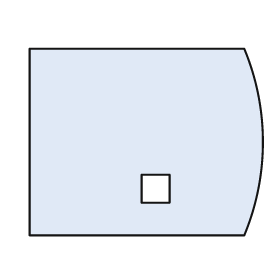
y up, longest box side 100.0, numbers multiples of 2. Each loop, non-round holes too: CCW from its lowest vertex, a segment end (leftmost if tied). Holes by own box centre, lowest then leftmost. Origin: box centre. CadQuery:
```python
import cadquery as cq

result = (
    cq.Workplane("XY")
    .moveTo(-50.0, -40.0)
    .lineTo(42.0, -40.0)
    .threePointArc((50.0, 0.0), (42.0, 40.0))
    .lineTo(-50.0, 40.0)
    .close()
    .moveTo(-2.0, -26.0)
    .lineTo(10.0, -26.0)
    .lineTo(10.0, -14.0)
    .lineTo(-2.0, -14.0)
    .close()
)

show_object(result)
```